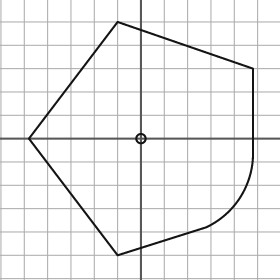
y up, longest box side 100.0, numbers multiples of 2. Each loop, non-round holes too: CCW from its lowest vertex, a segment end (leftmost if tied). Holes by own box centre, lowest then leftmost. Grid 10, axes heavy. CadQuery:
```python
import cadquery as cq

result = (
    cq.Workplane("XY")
    .moveTo(-10.0, -50.0)
    .lineTo(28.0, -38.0)
    .threePointArc((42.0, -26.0), (48.0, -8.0))
    .lineTo(48.0, 30.0)
    .lineTo(-10.0, 50.0)
    .lineTo(-48.0, 0.0)
    .close()
    .moveTo(0.0, 0.0)
    .circle(2.0)
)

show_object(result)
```